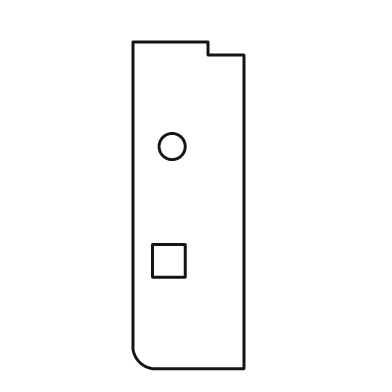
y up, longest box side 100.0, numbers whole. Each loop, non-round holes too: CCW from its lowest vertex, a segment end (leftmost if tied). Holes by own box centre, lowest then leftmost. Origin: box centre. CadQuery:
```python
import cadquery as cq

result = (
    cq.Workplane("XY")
    .moveTo(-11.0, -50.0)
    .lineTo(17.0, -50.0)
    .lineTo(17.0, 46.0)
    .lineTo(6.0, 46.0)
    .lineTo(6.0, 50.0)
    .lineTo(-17.0, 50.0)
    .lineTo(-17.0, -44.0)
    .threePointArc((-15.0, -48.0), (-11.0, -50.0))
    .close()
    .moveTo(-11.0, -22.0)
    .lineTo(-1.0, -22.0)
    .lineTo(-1.0, -12.0)
    .lineTo(-11.0, -12.0)
    .close()
    .moveTo(-5.0, 18.0)
    .circle(4.0)
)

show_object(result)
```